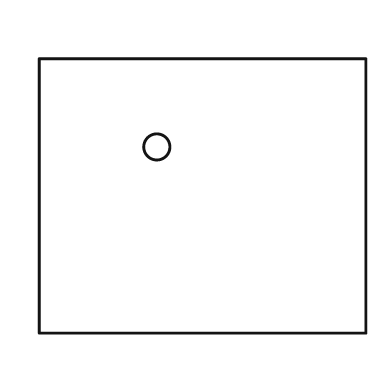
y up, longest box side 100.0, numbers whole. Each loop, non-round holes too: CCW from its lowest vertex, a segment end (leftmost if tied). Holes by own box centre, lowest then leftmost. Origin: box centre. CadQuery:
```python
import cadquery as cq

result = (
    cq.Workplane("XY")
    .moveTo(-50.0, -42.0)
    .lineTo(50.0, -42.0)
    .lineTo(50.0, 42.0)
    .lineTo(-50.0, 42.0)
    .close()
    .moveTo(-14.0, 15.0)
    .circle(4.0)
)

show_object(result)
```